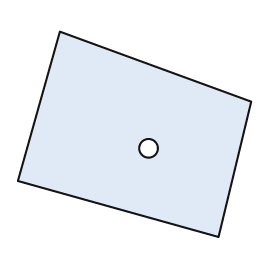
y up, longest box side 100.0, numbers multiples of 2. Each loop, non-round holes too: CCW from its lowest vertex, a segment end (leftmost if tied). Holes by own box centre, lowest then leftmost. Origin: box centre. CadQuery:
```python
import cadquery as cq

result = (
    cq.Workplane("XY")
    .moveTo(36.0, -44.0)
    .lineTo(50.0, 14.0)
    .lineTo(-32.0, 44.0)
    .lineTo(-50.0, -20.0)
    .close()
    .moveTo(6.0, -6.0)
    .circle(4.0)
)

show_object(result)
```